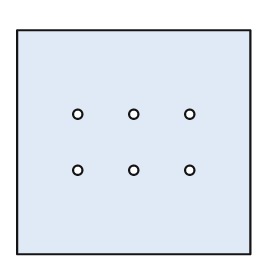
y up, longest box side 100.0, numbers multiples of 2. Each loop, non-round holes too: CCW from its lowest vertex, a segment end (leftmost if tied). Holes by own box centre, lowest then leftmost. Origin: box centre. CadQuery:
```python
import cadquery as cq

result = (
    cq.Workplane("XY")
    .moveTo(-50.0, -48.0)
    .lineTo(50.0, -48.0)
    .lineTo(50.0, 48.0)
    .lineTo(-50.0, 48.0)
    .close()
    .moveTo(-24.0, -12.0)
    .circle(2.0)
    .moveTo(0.0, -12.0)
    .circle(2.0)
    .moveTo(24.0, -12.0)
    .circle(2.0)
    .moveTo(-24.0, 12.0)
    .circle(2.0)
    .moveTo(0.0, 12.0)
    .circle(2.0)
    .moveTo(24.0, 12.0)
    .circle(2.0)
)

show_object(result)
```